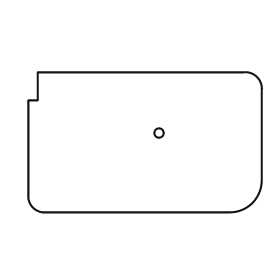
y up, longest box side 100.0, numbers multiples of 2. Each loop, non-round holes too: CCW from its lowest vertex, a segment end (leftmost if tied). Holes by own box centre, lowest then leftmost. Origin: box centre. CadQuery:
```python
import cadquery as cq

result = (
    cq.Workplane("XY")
    .moveTo(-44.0, -30.0)
    .lineTo(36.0, -30.0)
    .threePointArc((46.0, -26.0), (50.0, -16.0))
    .lineTo(50.0, 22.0)
    .threePointArc((48.0, 28.0), (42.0, 30.0))
    .lineTo(-46.0, 30.0)
    .lineTo(-46.0, 18.0)
    .lineTo(-50.0, 18.0)
    .lineTo(-50.0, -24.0)
    .threePointArc((-48.0, -28.0), (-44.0, -30.0))
    .close()
    .moveTo(6.0, 4.0)
    .circle(2.0)
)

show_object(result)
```